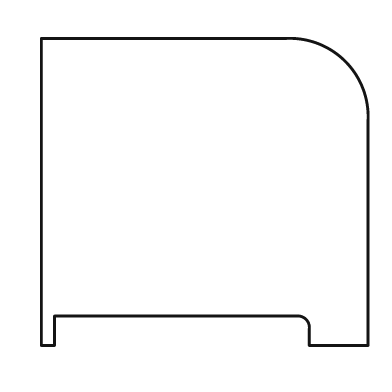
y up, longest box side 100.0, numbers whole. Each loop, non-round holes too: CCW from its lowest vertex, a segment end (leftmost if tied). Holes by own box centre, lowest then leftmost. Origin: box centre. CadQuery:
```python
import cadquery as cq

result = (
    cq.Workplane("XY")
    .moveTo(-50.0, -47.0)
    .lineTo(-46.0, -47.0)
    .lineTo(-46.0, -38.0)
    .lineTo(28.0, -38.0)
    .threePointArc((31.0, -39.0), (32.0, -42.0))
    .lineTo(32.0, -47.0)
    .lineTo(50.0, -47.0)
    .lineTo(50.0, 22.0)
    .threePointArc((43.0, 40.0), (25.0, 47.0))
    .lineTo(-50.0, 47.0)
    .close()
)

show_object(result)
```